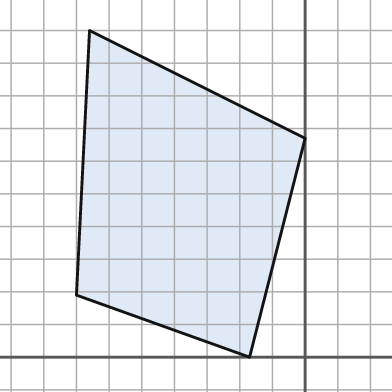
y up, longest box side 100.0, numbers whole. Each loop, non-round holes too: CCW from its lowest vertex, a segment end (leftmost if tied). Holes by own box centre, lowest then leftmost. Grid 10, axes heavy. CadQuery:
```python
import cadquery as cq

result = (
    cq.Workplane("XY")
    .moveTo(-17.0, 0.0)
    .lineTo(0.0, 67.0)
    .lineTo(-66.0, 100.0)
    .lineTo(-70.0, 19.0)
    .close()
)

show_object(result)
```